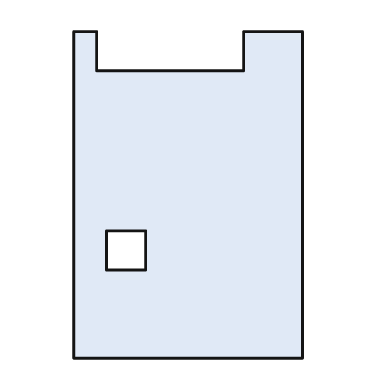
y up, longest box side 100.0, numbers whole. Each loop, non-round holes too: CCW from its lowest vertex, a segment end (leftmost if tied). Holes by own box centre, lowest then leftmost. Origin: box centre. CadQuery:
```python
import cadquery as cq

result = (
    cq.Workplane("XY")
    .moveTo(-35.0, -50.0)
    .lineTo(35.0, -50.0)
    .lineTo(35.0, 50.0)
    .lineTo(17.0, 50.0)
    .lineTo(17.0, 38.0)
    .lineTo(-28.0, 38.0)
    .lineTo(-28.0, 50.0)
    .lineTo(-35.0, 50.0)
    .close()
    .moveTo(-25.0, -23.0)
    .lineTo(-13.0, -23.0)
    .lineTo(-13.0, -11.0)
    .lineTo(-25.0, -11.0)
    .close()
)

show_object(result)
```